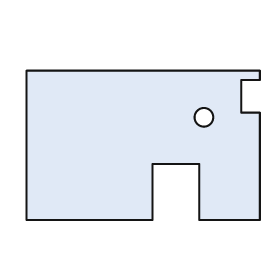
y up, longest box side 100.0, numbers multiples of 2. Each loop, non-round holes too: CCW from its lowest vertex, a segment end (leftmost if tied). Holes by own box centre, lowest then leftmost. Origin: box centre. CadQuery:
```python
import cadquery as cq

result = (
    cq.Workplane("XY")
    .moveTo(-50.0, -32.0)
    .lineTo(4.0, -32.0)
    .lineTo(4.0, -8.0)
    .lineTo(24.0, -8.0)
    .lineTo(24.0, -32.0)
    .lineTo(50.0, -32.0)
    .lineTo(50.0, 14.0)
    .lineTo(42.0, 14.0)
    .lineTo(42.0, 28.0)
    .lineTo(50.0, 28.0)
    .lineTo(50.0, 32.0)
    .lineTo(-50.0, 32.0)
    .close()
    .moveTo(26.0, 12.0)
    .circle(4.0)
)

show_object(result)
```